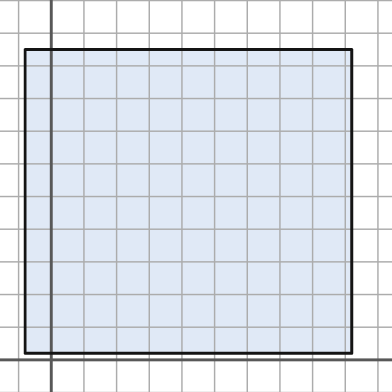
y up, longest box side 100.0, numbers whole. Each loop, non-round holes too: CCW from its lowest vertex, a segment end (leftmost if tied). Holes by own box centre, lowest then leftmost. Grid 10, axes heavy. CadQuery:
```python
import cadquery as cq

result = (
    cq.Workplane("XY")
    .moveTo(-8.0, 2.0)
    .lineTo(92.0, 2.0)
    .lineTo(92.0, 95.0)
    .lineTo(-8.0, 95.0)
    .close()
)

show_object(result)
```